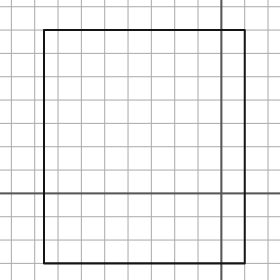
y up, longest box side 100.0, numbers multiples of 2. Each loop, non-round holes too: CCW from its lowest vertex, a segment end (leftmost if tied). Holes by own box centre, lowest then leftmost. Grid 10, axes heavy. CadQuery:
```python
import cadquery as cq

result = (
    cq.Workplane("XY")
    .moveTo(-76.0, -30.0)
    .lineTo(10.0, -30.0)
    .lineTo(10.0, 70.0)
    .lineTo(-76.0, 70.0)
    .close()
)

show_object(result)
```